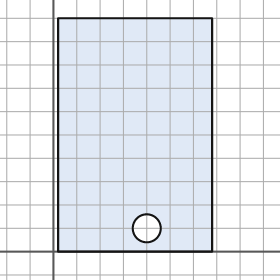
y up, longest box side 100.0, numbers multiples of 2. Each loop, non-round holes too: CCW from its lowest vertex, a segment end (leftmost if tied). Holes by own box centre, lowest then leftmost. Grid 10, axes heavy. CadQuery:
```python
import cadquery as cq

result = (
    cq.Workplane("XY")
    .moveTo(2.0, 0.0)
    .lineTo(68.0, 0.0)
    .lineTo(68.0, 100.0)
    .lineTo(2.0, 100.0)
    .close()
    .moveTo(40.0, 10.0)
    .circle(6.0)
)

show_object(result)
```